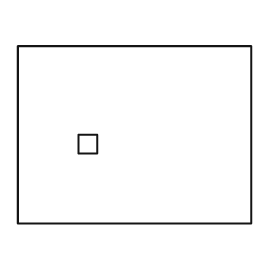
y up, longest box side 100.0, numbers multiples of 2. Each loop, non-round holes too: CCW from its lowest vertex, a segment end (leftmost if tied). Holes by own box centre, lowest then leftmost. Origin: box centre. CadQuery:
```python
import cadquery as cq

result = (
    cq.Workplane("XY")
    .moveTo(-50.0, -38.0)
    .lineTo(50.0, -38.0)
    .lineTo(50.0, 38.0)
    .lineTo(-50.0, 38.0)
    .close()
    .moveTo(-24.0, -8.0)
    .lineTo(-16.0, -8.0)
    .lineTo(-16.0, 0.0)
    .lineTo(-24.0, 0.0)
    .close()
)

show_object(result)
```